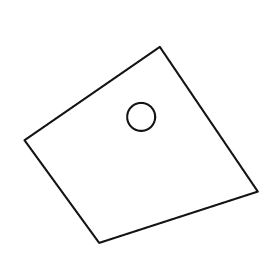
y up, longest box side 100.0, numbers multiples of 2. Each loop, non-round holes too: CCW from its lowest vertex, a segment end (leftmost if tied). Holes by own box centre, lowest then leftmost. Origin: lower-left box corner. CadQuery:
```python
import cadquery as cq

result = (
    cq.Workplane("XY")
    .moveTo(32.0, 0.0)
    .lineTo(100.0, 22.0)
    .lineTo(58.0, 84.0)
    .lineTo(0.0, 44.0)
    .close()
    .moveTo(50.0, 54.0)
    .circle(6.0)
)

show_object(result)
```